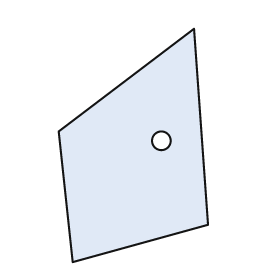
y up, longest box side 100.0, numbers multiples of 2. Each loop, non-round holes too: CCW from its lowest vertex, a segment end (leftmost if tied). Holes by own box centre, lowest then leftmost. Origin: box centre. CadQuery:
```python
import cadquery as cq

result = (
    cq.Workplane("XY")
    .moveTo(-26.0, -50.0)
    .lineTo(32.0, -34.0)
    .lineTo(26.0, 50.0)
    .lineTo(-32.0, 6.0)
    .close()
    .moveTo(12.0, 2.0)
    .circle(4.0)
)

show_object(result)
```